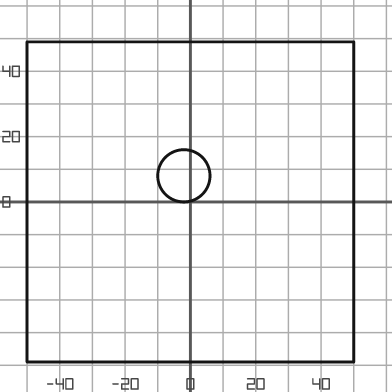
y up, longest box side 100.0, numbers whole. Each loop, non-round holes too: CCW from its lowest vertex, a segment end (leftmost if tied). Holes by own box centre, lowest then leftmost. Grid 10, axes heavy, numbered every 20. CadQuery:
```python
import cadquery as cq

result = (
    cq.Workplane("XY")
    .moveTo(-50.0, -49.0)
    .lineTo(50.0, -49.0)
    .lineTo(50.0, 49.0)
    .lineTo(-50.0, 49.0)
    .close()
    .moveTo(-2.0, 8.0)
    .circle(8.0)
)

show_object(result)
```